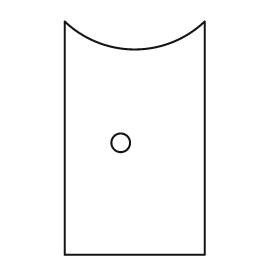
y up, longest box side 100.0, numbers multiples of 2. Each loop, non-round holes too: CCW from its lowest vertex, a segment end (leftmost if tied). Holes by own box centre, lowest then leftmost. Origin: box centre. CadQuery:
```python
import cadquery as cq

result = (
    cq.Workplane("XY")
    .moveTo(-30.0, -50.0)
    .lineTo(30.0, -50.0)
    .lineTo(30.0, 50.0)
    .threePointArc((0.0, 38.0), (-30.0, 50.0))
    .close()
    .moveTo(-6.0, -2.0)
    .circle(4.0)
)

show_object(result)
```